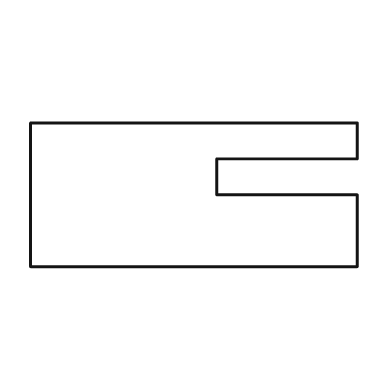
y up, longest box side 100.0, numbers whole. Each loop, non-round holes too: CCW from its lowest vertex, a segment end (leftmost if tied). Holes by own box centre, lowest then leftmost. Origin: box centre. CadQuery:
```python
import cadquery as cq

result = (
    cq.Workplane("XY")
    .moveTo(-50.0, -22.0)
    .lineTo(50.0, -22.0)
    .lineTo(50.0, 0.0)
    .lineTo(7.0, 0.0)
    .lineTo(7.0, 11.0)
    .lineTo(50.0, 11.0)
    .lineTo(50.0, 22.0)
    .lineTo(-50.0, 22.0)
    .close()
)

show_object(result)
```